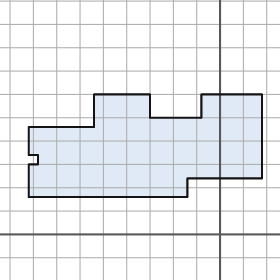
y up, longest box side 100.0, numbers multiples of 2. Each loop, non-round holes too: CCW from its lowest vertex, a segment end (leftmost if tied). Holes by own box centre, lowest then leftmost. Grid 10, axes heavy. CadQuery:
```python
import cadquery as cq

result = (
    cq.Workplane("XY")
    .moveTo(-82.0, 16.0)
    .lineTo(-14.0, 16.0)
    .lineTo(-14.0, 24.0)
    .lineTo(18.0, 24.0)
    .lineTo(18.0, 60.0)
    .lineTo(-8.0, 60.0)
    .lineTo(-8.0, 50.0)
    .lineTo(-30.0, 50.0)
    .lineTo(-30.0, 60.0)
    .lineTo(-54.0, 60.0)
    .lineTo(-54.0, 46.0)
    .lineTo(-82.0, 46.0)
    .lineTo(-82.0, 34.0)
    .lineTo(-78.0, 34.0)
    .lineTo(-78.0, 30.0)
    .lineTo(-82.0, 30.0)
    .close()
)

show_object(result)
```